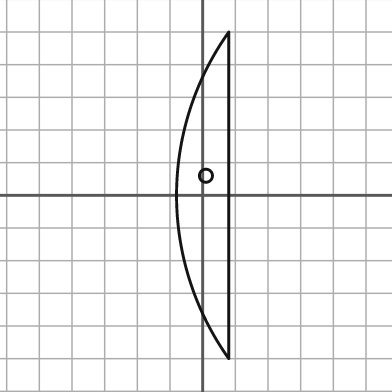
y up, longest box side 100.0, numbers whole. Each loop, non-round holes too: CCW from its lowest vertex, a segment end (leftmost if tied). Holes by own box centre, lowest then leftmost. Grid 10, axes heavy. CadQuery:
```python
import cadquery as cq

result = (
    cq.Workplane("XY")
    .moveTo(8.0, -50.0)
    .lineTo(8.0, 50.0)
    .threePointArc((-8.0, 0.0), (8.0, -50.0))
    .close()
    .moveTo(1.0, 6.0)
    .circle(2.0)
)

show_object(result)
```